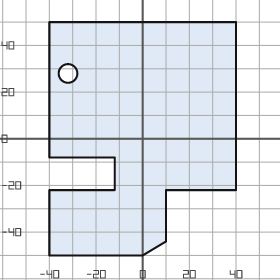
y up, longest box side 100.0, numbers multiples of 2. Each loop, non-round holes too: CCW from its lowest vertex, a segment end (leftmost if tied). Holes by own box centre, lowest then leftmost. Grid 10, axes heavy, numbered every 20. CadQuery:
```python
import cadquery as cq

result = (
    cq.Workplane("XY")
    .moveTo(-40.0, -50.0)
    .lineTo(0.0, -50.0)
    .lineTo(10.0, -44.0)
    .lineTo(10.0, -22.0)
    .lineTo(40.0, -22.0)
    .lineTo(40.0, 50.0)
    .lineTo(-40.0, 50.0)
    .lineTo(-40.0, -8.0)
    .lineTo(-12.0, -8.0)
    .lineTo(-12.0, -22.0)
    .lineTo(-40.0, -22.0)
    .close()
    .moveTo(-32.0, 28.0)
    .circle(4.0)
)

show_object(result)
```